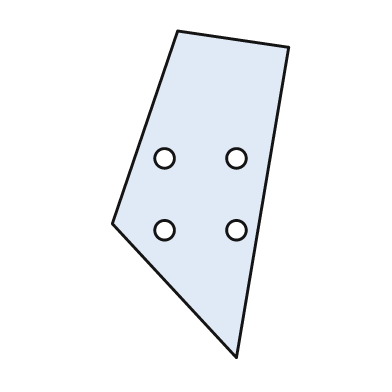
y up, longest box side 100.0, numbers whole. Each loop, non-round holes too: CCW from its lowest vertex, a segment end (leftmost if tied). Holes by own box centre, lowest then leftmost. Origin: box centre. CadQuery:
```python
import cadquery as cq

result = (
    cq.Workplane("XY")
    .moveTo(11.0, -50.0)
    .lineTo(27.0, 45.0)
    .lineTo(-7.0, 50.0)
    .lineTo(-27.0, -9.0)
    .close()
    .moveTo(-11.0, -11.0)
    .circle(3.0)
    .moveTo(11.0, -11.0)
    .circle(3.0)
    .moveTo(-11.0, 11.0)
    .circle(3.0)
    .moveTo(11.0, 11.0)
    .circle(3.0)
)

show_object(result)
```